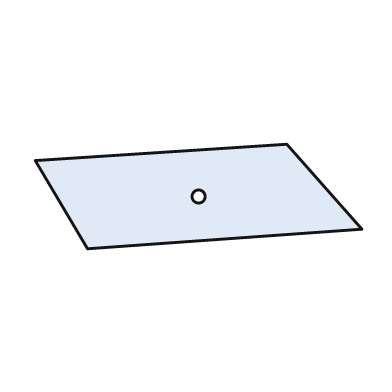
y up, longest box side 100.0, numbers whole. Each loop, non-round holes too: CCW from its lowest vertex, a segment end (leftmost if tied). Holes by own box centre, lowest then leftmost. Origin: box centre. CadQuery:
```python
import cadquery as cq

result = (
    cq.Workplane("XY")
    .moveTo(-34.0, -16.0)
    .lineTo(50.0, -10.0)
    .lineTo(27.0, 16.0)
    .lineTo(-50.0, 11.0)
    .close()
    .moveTo(0.0, 0.0)
    .circle(2.0)
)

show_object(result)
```